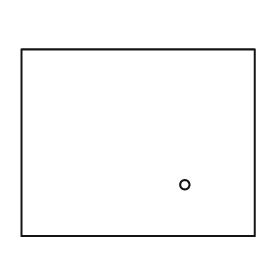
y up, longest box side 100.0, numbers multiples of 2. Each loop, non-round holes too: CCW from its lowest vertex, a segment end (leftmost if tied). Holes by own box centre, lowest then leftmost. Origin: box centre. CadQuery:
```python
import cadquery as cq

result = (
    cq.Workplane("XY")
    .moveTo(-50.0, -40.0)
    .lineTo(50.0, -40.0)
    .lineTo(50.0, 40.0)
    .lineTo(-50.0, 40.0)
    .close()
    .moveTo(20.0, -18.0)
    .circle(2.0)
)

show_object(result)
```